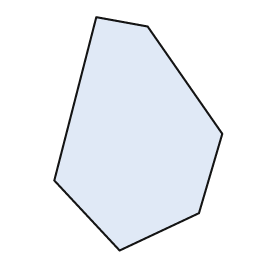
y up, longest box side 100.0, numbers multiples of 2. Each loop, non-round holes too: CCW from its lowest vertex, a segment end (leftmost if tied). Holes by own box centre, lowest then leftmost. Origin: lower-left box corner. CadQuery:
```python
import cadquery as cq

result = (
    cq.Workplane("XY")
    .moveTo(28.0, 0.0)
    .lineTo(62.0, 16.0)
    .lineTo(72.0, 50.0)
    .lineTo(40.0, 96.0)
    .lineTo(18.0, 100.0)
    .lineTo(0.0, 30.0)
    .close()
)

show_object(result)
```